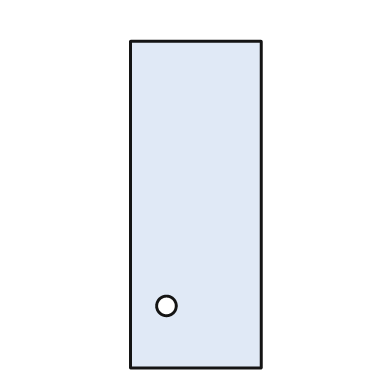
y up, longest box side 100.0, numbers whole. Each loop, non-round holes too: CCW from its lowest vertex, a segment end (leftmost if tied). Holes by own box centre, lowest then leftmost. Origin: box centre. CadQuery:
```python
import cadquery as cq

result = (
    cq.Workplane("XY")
    .moveTo(-20.0, -50.0)
    .lineTo(20.0, -50.0)
    .lineTo(20.0, 50.0)
    .lineTo(-20.0, 50.0)
    .close()
    .moveTo(-9.0, -31.0)
    .circle(3.0)
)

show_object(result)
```